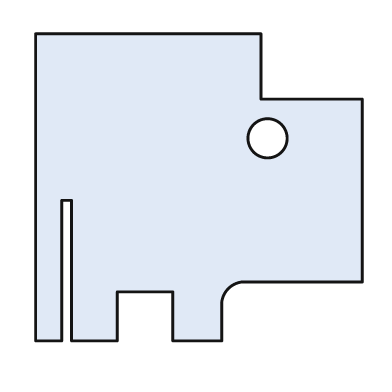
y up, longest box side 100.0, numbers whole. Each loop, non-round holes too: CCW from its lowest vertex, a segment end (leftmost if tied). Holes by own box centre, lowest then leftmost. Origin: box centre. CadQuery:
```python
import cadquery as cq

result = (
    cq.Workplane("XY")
    .moveTo(-50.0, -47.0)
    .lineTo(-42.0, -47.0)
    .lineTo(-42.0, -4.0)
    .lineTo(-39.0, -4.0)
    .lineTo(-39.0, -47.0)
    .lineTo(-25.0, -47.0)
    .lineTo(-25.0, -32.0)
    .lineTo(-8.0, -32.0)
    .lineTo(-8.0, -47.0)
    .lineTo(7.0, -47.0)
    .lineTo(7.0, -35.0)
    .threePointArc((9.0, -31.0), (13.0, -29.0))
    .lineTo(50.0, -29.0)
    .lineTo(50.0, 27.0)
    .lineTo(19.0, 27.0)
    .lineTo(19.0, 47.0)
    .lineTo(-50.0, 47.0)
    .close()
    .moveTo(21.0, 15.0)
    .circle(6.0)
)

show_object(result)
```